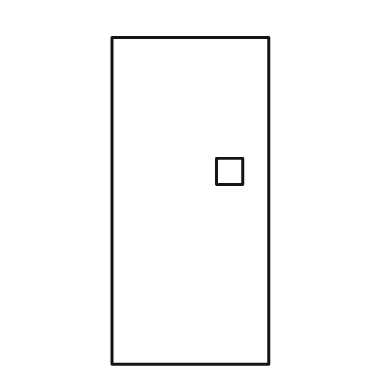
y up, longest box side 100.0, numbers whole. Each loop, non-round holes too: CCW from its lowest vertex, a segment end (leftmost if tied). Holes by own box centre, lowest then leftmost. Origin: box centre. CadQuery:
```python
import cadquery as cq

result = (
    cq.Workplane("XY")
    .moveTo(-24.0, -50.0)
    .lineTo(24.0, -50.0)
    .lineTo(24.0, 50.0)
    .lineTo(-24.0, 50.0)
    .close()
    .moveTo(8.0, 5.0)
    .lineTo(16.0, 5.0)
    .lineTo(16.0, 13.0)
    .lineTo(8.0, 13.0)
    .close()
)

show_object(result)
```